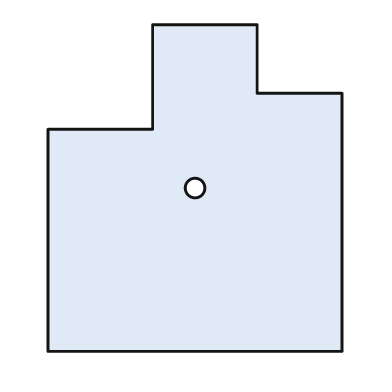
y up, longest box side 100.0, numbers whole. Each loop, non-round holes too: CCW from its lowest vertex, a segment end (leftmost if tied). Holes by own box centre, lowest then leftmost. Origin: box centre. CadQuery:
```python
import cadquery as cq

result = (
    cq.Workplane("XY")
    .moveTo(-45.0, -50.0)
    .lineTo(45.0, -50.0)
    .lineTo(45.0, 29.0)
    .lineTo(19.0, 29.0)
    .lineTo(19.0, 50.0)
    .lineTo(-13.0, 50.0)
    .lineTo(-13.0, 18.0)
    .lineTo(-45.0, 18.0)
    .close()
    .moveTo(0.0, 0.0)
    .circle(3.0)
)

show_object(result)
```